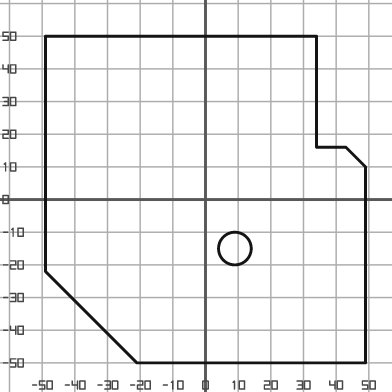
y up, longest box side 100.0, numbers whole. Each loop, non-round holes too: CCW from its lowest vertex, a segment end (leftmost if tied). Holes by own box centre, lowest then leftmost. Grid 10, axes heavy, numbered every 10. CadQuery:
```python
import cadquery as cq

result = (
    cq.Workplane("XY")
    .moveTo(-21.0, -50.0)
    .lineTo(49.0, -50.0)
    .lineTo(49.0, 10.0)
    .lineTo(43.0, 16.0)
    .lineTo(34.0, 16.0)
    .lineTo(34.0, 50.0)
    .lineTo(-49.0, 50.0)
    .lineTo(-49.0, -22.0)
    .close()
    .moveTo(9.0, -15.0)
    .circle(5.0)
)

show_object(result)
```